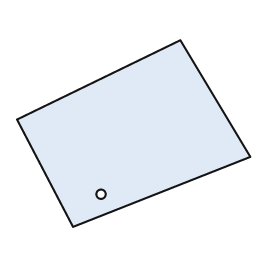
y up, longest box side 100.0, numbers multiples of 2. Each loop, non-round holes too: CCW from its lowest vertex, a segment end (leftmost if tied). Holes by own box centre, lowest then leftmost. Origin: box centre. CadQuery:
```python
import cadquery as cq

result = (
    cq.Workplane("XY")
    .moveTo(-26.0, -40.0)
    .lineTo(50.0, -10.0)
    .lineTo(20.0, 40.0)
    .lineTo(-50.0, 6.0)
    .close()
    .moveTo(-14.0, -26.0)
    .circle(2.0)
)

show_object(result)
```